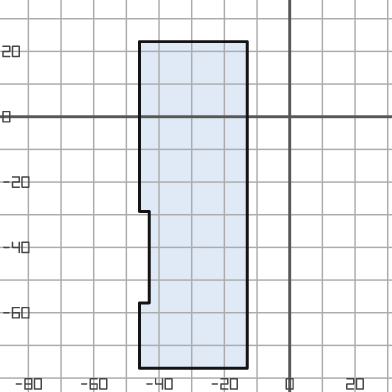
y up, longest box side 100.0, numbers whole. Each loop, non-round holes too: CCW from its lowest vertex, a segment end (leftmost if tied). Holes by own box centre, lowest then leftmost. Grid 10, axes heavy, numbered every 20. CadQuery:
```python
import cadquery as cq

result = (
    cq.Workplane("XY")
    .moveTo(-46.0, -77.0)
    .lineTo(-13.0, -77.0)
    .lineTo(-13.0, 23.0)
    .lineTo(-46.0, 23.0)
    .lineTo(-46.0, -29.0)
    .lineTo(-43.0, -29.0)
    .lineTo(-43.0, -57.0)
    .lineTo(-46.0, -57.0)
    .close()
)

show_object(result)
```